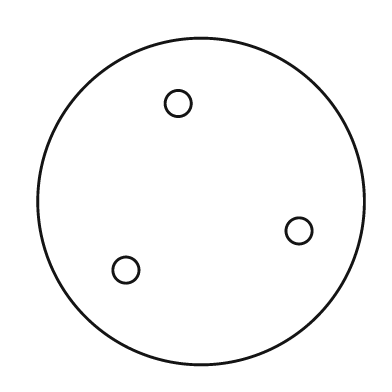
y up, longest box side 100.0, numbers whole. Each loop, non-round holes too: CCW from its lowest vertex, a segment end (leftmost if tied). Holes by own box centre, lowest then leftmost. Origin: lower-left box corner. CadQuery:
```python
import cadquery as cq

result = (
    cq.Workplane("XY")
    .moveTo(50.0, 50.0)
    .circle(50.0)
    .moveTo(27.0, 29.0)
    .circle(4.0)
    .moveTo(80.0, 41.0)
    .circle(4.0)
    .moveTo(43.0, 80.0)
    .circle(4.0)
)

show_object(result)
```